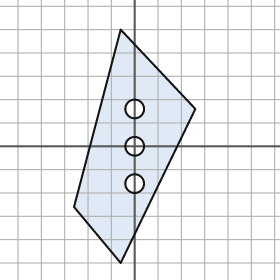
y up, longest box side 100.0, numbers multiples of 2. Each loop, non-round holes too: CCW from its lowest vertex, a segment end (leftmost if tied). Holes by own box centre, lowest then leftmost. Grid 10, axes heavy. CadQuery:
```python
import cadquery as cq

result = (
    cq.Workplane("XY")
    .moveTo(-6.0, -50.0)
    .lineTo(26.0, 16.0)
    .lineTo(-6.0, 50.0)
    .lineTo(-26.0, -26.0)
    .close()
    .moveTo(0.0, -16.0)
    .circle(4.0)
    .moveTo(0.0, 0.0)
    .circle(4.0)
    .moveTo(0.0, 16.0)
    .circle(4.0)
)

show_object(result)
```